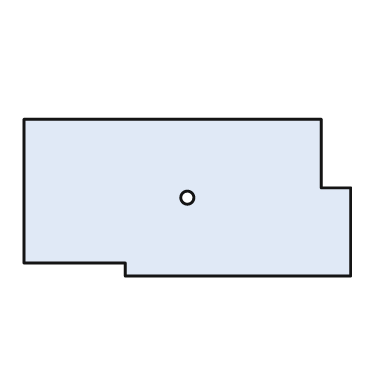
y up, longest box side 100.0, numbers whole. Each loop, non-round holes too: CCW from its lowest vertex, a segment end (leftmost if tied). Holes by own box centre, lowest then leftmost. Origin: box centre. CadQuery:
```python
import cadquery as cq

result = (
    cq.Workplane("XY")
    .moveTo(-19.0, -24.0)
    .lineTo(50.0, -24.0)
    .lineTo(50.0, 3.0)
    .lineTo(41.0, 3.0)
    .lineTo(41.0, 24.0)
    .lineTo(-50.0, 24.0)
    .lineTo(-50.0, -20.0)
    .lineTo(-19.0, -20.0)
    .close()
    .moveTo(0.0, 0.0)
    .circle(2.0)
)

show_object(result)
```